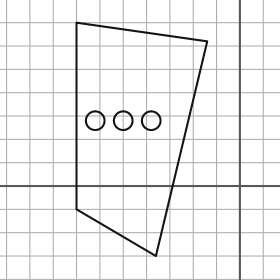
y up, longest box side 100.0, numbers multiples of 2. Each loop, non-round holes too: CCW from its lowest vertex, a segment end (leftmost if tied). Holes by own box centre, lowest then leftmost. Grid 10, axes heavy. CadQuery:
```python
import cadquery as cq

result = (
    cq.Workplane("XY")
    .moveTo(-36.0, -30.0)
    .lineTo(-14.0, 62.0)
    .lineTo(-70.0, 70.0)
    .lineTo(-70.0, -10.0)
    .close()
    .moveTo(-62.0, 28.0)
    .circle(4.0)
    .moveTo(-50.0, 28.0)
    .circle(4.0)
    .moveTo(-38.0, 28.0)
    .circle(4.0)
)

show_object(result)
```